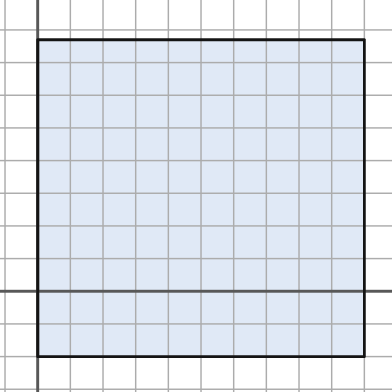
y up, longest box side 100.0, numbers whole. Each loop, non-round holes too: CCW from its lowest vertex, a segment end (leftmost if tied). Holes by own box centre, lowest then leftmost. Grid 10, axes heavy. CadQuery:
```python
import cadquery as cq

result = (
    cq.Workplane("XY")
    .moveTo(0.0, -20.0)
    .lineTo(100.0, -20.0)
    .lineTo(100.0, 77.0)
    .lineTo(0.0, 77.0)
    .close()
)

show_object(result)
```